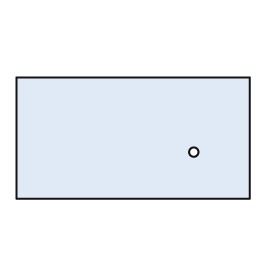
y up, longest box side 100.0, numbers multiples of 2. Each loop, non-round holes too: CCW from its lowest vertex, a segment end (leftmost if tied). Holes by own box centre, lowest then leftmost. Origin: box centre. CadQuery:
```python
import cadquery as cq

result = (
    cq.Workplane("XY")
    .moveTo(-50.0, -26.0)
    .lineTo(50.0, -26.0)
    .lineTo(50.0, 26.0)
    .lineTo(-50.0, 26.0)
    .close()
    .moveTo(26.0, -6.0)
    .circle(2.0)
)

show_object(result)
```